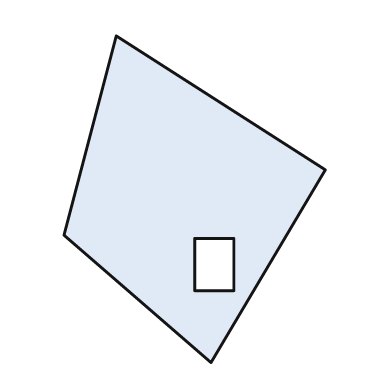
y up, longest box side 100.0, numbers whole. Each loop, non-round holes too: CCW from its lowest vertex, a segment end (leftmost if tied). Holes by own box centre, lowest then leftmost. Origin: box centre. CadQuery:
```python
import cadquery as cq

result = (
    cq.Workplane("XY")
    .moveTo(5.0, -50.0)
    .lineTo(40.0, 9.0)
    .lineTo(-24.0, 50.0)
    .lineTo(-40.0, -11.0)
    .close()
    .moveTo(0.0, -28.0)
    .lineTo(12.0, -28.0)
    .lineTo(12.0, -12.0)
    .lineTo(0.0, -12.0)
    .close()
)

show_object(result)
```